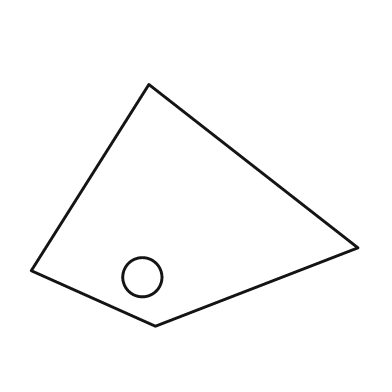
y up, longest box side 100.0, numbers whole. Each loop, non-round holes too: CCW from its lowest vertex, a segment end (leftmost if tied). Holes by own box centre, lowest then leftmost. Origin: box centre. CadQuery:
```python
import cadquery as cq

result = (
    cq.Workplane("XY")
    .moveTo(-12.0, -37.0)
    .lineTo(50.0, -13.0)
    .lineTo(-14.0, 37.0)
    .lineTo(-50.0, -20.0)
    .close()
    .moveTo(-16.0, -22.0)
    .circle(6.0)
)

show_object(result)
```